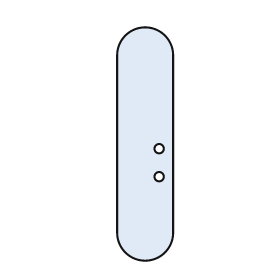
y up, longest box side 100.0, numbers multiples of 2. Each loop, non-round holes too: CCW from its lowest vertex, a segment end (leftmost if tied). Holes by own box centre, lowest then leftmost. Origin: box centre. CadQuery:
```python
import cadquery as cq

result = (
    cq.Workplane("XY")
    .moveTo(-12.0, -38.0)
    .threePointArc((0.0, -50.0), (12.0, -38.0))
    .lineTo(12.0, 38.0)
    .threePointArc((0.0, 50.0), (-12.0, 38.0))
    .close()
    .moveTo(6.0, -14.0)
    .circle(2.0)
    .moveTo(6.0, -2.0)
    .circle(2.0)
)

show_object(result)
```